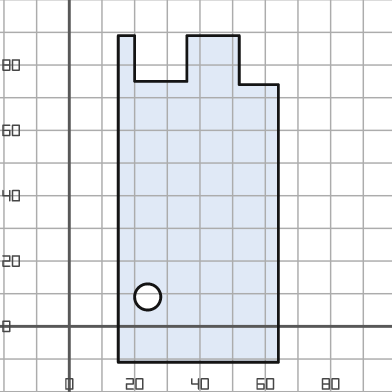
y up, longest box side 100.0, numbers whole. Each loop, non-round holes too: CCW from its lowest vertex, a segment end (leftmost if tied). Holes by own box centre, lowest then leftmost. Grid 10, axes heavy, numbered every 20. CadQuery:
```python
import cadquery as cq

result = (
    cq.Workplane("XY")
    .moveTo(15.0, -11.0)
    .lineTo(64.0, -11.0)
    .lineTo(64.0, 74.0)
    .lineTo(52.0, 74.0)
    .lineTo(52.0, 89.0)
    .lineTo(36.0, 89.0)
    .lineTo(36.0, 75.0)
    .lineTo(20.0, 75.0)
    .lineTo(20.0, 89.0)
    .lineTo(15.0, 89.0)
    .close()
    .moveTo(24.0, 9.0)
    .circle(4.0)
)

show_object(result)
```